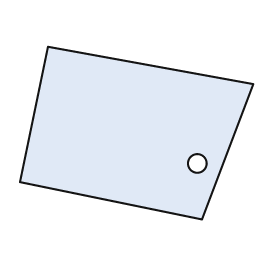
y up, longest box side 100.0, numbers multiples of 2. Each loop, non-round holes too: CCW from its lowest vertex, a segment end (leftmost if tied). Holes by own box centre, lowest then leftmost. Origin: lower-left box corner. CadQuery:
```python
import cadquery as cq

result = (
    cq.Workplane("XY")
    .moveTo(78.0, 0.0)
    .lineTo(100.0, 58.0)
    .lineTo(12.0, 74.0)
    .lineTo(0.0, 16.0)
    .close()
    .moveTo(76.0, 24.0)
    .circle(4.0)
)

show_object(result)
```